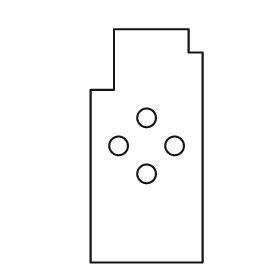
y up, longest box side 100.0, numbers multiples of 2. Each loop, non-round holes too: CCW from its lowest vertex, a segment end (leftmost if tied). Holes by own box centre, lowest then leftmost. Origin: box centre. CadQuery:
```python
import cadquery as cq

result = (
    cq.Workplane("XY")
    .moveTo(-24.0, -50.0)
    .lineTo(24.0, -50.0)
    .lineTo(24.0, 40.0)
    .lineTo(18.0, 40.0)
    .lineTo(18.0, 50.0)
    .lineTo(-14.0, 50.0)
    .lineTo(-14.0, 24.0)
    .lineTo(-24.0, 24.0)
    .close()
    .moveTo(0.0, -12.0)
    .circle(4.0)
    .moveTo(-12.0, 0.0)
    .circle(4.0)
    .moveTo(12.0, 0.0)
    .circle(4.0)
    .moveTo(0.0, 12.0)
    .circle(4.0)
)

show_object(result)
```